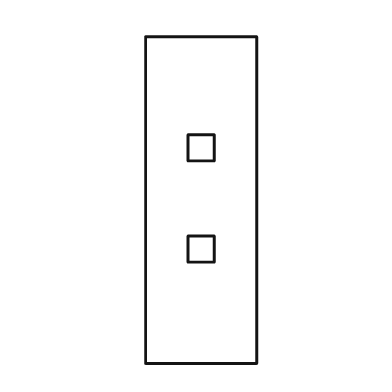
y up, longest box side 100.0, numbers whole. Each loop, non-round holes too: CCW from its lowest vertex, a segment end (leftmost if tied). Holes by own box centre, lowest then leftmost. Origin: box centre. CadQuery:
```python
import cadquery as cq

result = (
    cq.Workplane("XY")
    .moveTo(-17.0, -50.0)
    .lineTo(17.0, -50.0)
    .lineTo(17.0, 50.0)
    .lineTo(-17.0, 50.0)
    .close()
    .moveTo(-4.0, -19.0)
    .lineTo(4.0, -19.0)
    .lineTo(4.0, -11.0)
    .lineTo(-4.0, -11.0)
    .close()
    .moveTo(-4.0, 12.0)
    .lineTo(4.0, 12.0)
    .lineTo(4.0, 20.0)
    .lineTo(-4.0, 20.0)
    .close()
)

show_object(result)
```